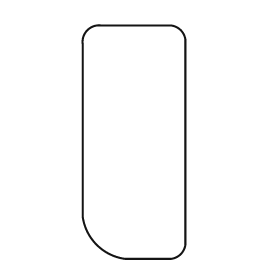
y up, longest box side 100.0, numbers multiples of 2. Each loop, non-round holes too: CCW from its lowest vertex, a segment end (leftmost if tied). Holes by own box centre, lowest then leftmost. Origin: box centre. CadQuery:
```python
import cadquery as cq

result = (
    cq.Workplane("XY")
    .moveTo(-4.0, -50.0)
    .lineTo(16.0, -50.0)
    .threePointArc((20.0, -48.0), (22.0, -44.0))
    .lineTo(22.0, 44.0)
    .threePointArc((20.0, 48.0), (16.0, 50.0))
    .lineTo(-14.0, 50.0)
    .threePointArc((-20.0, 48.0), (-22.0, 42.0))
    .lineTo(-22.0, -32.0)
    .threePointArc((-16.0, -44.0), (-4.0, -50.0))
    .close()
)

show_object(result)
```